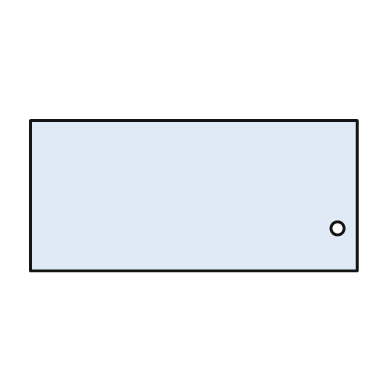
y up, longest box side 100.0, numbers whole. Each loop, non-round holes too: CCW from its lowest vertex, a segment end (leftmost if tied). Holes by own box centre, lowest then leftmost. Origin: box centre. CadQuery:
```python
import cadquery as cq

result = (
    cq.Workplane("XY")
    .moveTo(-50.0, -23.0)
    .lineTo(50.0, -23.0)
    .lineTo(50.0, 23.0)
    .lineTo(-50.0, 23.0)
    .close()
    .moveTo(44.0, -10.0)
    .circle(2.0)
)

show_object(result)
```